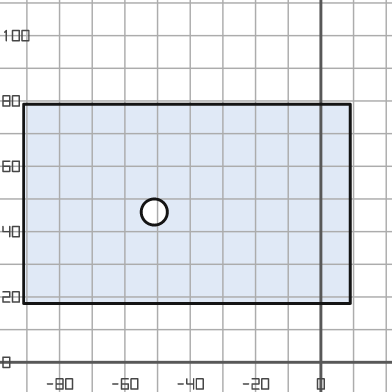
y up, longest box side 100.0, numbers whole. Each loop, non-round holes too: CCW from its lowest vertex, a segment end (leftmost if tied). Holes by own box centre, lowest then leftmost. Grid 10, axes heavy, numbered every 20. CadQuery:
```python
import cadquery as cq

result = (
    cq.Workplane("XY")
    .moveTo(-91.0, 18.0)
    .lineTo(9.0, 18.0)
    .lineTo(9.0, 79.0)
    .lineTo(-91.0, 79.0)
    .close()
    .moveTo(-51.0, 46.0)
    .circle(4.0)
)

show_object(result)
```